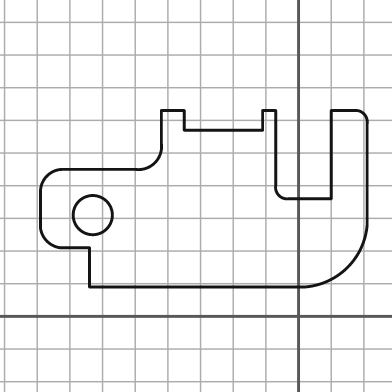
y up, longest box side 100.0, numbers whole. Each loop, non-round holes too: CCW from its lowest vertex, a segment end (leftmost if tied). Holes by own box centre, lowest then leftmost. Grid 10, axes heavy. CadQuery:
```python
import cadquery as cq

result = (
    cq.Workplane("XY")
    .moveTo(-64.0, 9.0)
    .lineTo(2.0, 9.0)
    .threePointArc((15.0, 15.0), (21.0, 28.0))
    .lineTo(21.0, 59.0)
    .threePointArc((20.0, 62.0), (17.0, 63.0))
    .lineTo(10.0, 63.0)
    .lineTo(10.0, 36.0)
    .lineTo(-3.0, 36.0)
    .threePointArc((-6.0, 37.0), (-7.0, 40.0))
    .lineTo(-7.0, 63.0)
    .lineTo(-11.0, 63.0)
    .lineTo(-11.0, 57.0)
    .lineTo(-35.0, 57.0)
    .lineTo(-35.0, 63.0)
    .lineTo(-42.0, 63.0)
    .lineTo(-42.0, 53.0)
    .threePointArc((-44.0, 47.0), (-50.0, 45.0))
    .lineTo(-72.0, 45.0)
    .threePointArc((-77.0, 43.0), (-79.0, 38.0))
    .lineTo(-79.0, 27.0)
    .threePointArc((-77.0, 23.0), (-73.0, 21.0))
    .lineTo(-64.0, 21.0)
    .close()
    .moveTo(-63.0, 31.0)
    .circle(6.0)
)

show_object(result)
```